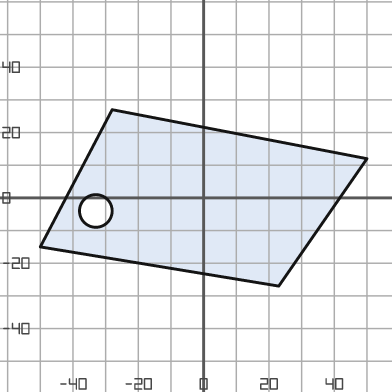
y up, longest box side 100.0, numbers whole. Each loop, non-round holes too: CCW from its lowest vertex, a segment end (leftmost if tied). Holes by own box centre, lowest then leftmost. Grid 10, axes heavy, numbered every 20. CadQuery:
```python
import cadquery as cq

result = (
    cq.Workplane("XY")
    .moveTo(23.0, -27.0)
    .lineTo(50.0, 12.0)
    .lineTo(-28.0, 27.0)
    .lineTo(-50.0, -15.0)
    .close()
    .moveTo(-33.0, -4.0)
    .circle(5.0)
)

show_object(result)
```